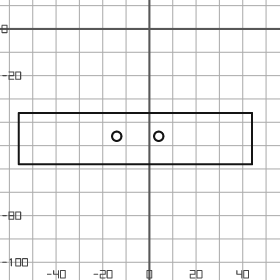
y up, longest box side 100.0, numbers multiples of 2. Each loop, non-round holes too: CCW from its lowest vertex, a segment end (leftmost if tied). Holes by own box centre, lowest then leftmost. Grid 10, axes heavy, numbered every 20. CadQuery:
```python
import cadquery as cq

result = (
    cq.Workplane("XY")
    .moveTo(-56.0, -58.0)
    .lineTo(44.0, -58.0)
    .lineTo(44.0, -36.0)
    .lineTo(-56.0, -36.0)
    .close()
    .moveTo(-14.0, -46.0)
    .circle(2.0)
    .moveTo(4.0, -46.0)
    .circle(2.0)
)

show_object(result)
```